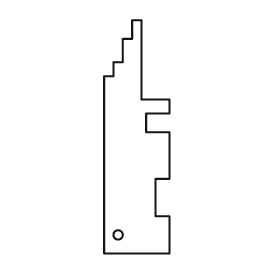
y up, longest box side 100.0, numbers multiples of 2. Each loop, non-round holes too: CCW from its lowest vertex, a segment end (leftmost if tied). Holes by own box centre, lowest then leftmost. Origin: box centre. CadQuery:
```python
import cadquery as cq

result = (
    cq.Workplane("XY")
    .moveTo(-14.0, -50.0)
    .lineTo(14.0, -50.0)
    .lineTo(14.0, -34.0)
    .lineTo(8.0, -34.0)
    .lineTo(8.0, -18.0)
    .lineTo(14.0, -18.0)
    .lineTo(14.0, 2.0)
    .lineTo(4.0, 2.0)
    .lineTo(4.0, 10.0)
    .lineTo(14.0, 10.0)
    .lineTo(14.0, 16.0)
    .lineTo(2.0, 16.0)
    .lineTo(2.0, 50.0)
    .lineTo(-2.0, 50.0)
    .lineTo(-2.0, 42.0)
    .lineTo(-6.0, 42.0)
    .lineTo(-6.0, 32.0)
    .lineTo(-10.0, 32.0)
    .lineTo(-10.0, 26.0)
    .lineTo(-14.0, 26.0)
    .close()
    .moveTo(-8.0, -42.0)
    .circle(2.0)
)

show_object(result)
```